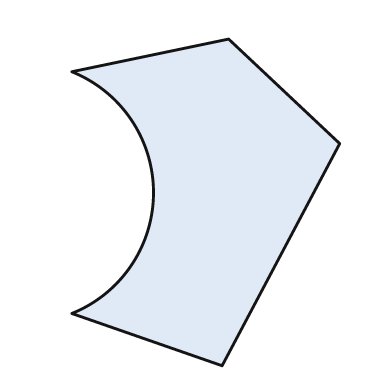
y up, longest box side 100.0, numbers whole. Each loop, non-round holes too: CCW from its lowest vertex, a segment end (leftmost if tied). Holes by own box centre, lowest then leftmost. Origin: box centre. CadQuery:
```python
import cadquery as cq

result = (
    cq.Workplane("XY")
    .moveTo(5.0, -50.0)
    .lineTo(41.0, 18.0)
    .lineTo(7.0, 50.0)
    .lineTo(-41.0, 40.0)
    .threePointArc((-16.0, 3.0), (-41.0, -34.0))
    .close()
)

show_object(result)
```